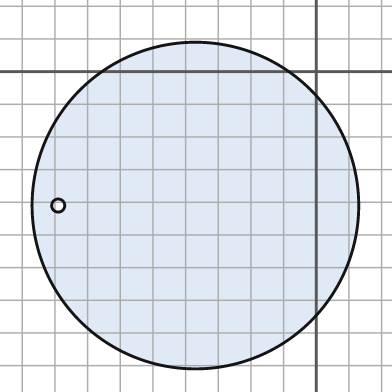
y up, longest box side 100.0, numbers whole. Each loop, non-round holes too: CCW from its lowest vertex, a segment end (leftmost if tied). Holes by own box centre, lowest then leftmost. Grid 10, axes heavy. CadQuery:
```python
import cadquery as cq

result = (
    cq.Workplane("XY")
    .moveTo(-37.0, -41.0)
    .circle(50.0)
    .moveTo(-79.0, -41.0)
    .circle(2.0)
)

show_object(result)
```